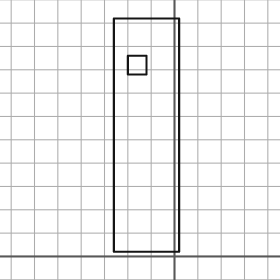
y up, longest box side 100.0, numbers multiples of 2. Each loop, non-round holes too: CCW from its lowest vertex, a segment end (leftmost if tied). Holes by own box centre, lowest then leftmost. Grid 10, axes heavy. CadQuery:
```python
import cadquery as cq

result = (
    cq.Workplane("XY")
    .moveTo(-26.0, 2.0)
    .lineTo(2.0, 2.0)
    .lineTo(2.0, 102.0)
    .lineTo(-26.0, 102.0)
    .close()
    .moveTo(-20.0, 78.0)
    .lineTo(-12.0, 78.0)
    .lineTo(-12.0, 86.0)
    .lineTo(-20.0, 86.0)
    .close()
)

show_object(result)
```